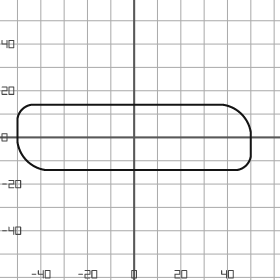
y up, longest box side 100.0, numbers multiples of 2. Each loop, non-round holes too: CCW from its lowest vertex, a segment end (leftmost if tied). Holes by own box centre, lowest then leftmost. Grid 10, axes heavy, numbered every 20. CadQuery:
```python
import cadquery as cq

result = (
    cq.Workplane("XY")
    .moveTo(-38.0, -14.0)
    .lineTo(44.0, -14.0)
    .threePointArc((48.0, -12.0), (50.0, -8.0))
    .lineTo(50.0, 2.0)
    .threePointArc((46.0, 10.0), (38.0, 14.0))
    .lineTo(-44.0, 14.0)
    .threePointArc((-48.0, 12.0), (-50.0, 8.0))
    .lineTo(-50.0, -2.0)
    .threePointArc((-46.0, -10.0), (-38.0, -14.0))
    .close()
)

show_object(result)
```